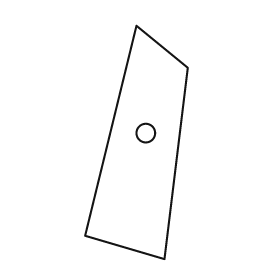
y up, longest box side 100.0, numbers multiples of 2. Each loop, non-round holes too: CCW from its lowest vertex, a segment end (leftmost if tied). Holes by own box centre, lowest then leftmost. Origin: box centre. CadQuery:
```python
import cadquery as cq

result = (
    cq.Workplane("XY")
    .moveTo(12.0, -50.0)
    .lineTo(22.0, 32.0)
    .lineTo(0.0, 50.0)
    .lineTo(-22.0, -40.0)
    .close()
    .moveTo(4.0, 4.0)
    .circle(4.0)
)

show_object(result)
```